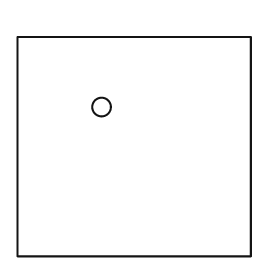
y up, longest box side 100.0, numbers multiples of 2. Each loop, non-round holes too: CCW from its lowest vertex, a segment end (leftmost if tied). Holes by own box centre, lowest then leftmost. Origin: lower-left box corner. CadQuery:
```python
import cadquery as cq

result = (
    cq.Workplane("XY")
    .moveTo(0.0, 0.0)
    .lineTo(100.0, 0.0)
    .lineTo(100.0, 94.0)
    .lineTo(0.0, 94.0)
    .close()
    .moveTo(36.0, 64.0)
    .circle(4.0)
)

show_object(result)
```